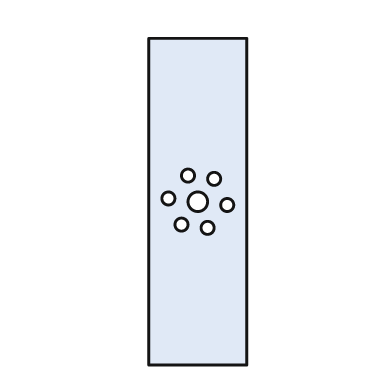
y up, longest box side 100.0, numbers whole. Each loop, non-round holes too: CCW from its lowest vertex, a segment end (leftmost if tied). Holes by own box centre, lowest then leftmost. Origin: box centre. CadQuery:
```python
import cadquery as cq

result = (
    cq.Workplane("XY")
    .moveTo(-15.0, -50.0)
    .lineTo(15.0, -50.0)
    .lineTo(15.0, 50.0)
    .lineTo(-15.0, 50.0)
    .close()
    .moveTo(3.0, -8.0)
    .circle(2.0)
    .moveTo(-5.0, -7.0)
    .circle(2.0)
    .moveTo(9.0, -1.0)
    .circle(2.0)
    .moveTo(0.0, 0.0)
    .circle(3.0)
    .moveTo(-9.0, 1.0)
    .circle(2.0)
    .moveTo(5.0, 7.0)
    .circle(2.0)
    .moveTo(-3.0, 8.0)
    .circle(2.0)
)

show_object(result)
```